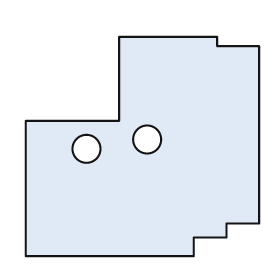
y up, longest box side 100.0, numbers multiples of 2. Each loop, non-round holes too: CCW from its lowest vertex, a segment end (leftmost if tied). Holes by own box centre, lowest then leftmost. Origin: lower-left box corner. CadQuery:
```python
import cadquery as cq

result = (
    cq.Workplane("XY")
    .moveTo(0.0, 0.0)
    .lineTo(72.0, 0.0)
    .lineTo(72.0, 8.0)
    .lineTo(86.0, 8.0)
    .lineTo(86.0, 14.0)
    .lineTo(100.0, 14.0)
    .lineTo(100.0, 90.0)
    .lineTo(82.0, 90.0)
    .lineTo(82.0, 94.0)
    .lineTo(40.0, 94.0)
    .lineTo(40.0, 58.0)
    .lineTo(0.0, 58.0)
    .close()
    .moveTo(26.0, 46.0)
    .circle(6.0)
    .moveTo(52.0, 50.0)
    .circle(6.0)
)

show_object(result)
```